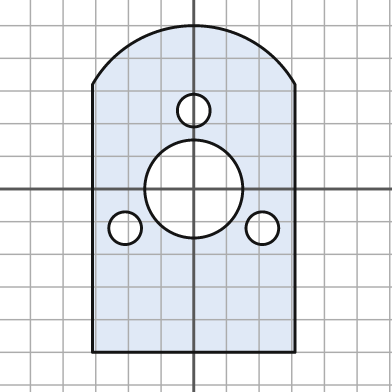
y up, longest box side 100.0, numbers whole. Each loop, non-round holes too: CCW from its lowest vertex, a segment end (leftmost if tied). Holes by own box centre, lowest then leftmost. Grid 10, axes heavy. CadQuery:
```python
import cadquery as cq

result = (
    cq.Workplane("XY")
    .moveTo(-31.0, -50.0)
    .lineTo(31.0, -50.0)
    .lineTo(31.0, 32.0)
    .threePointArc((0.0, 50.0), (-31.0, 32.0))
    .close()
    .moveTo(-21.0, -12.0)
    .circle(5.0)
    .moveTo(21.0, -12.0)
    .circle(5.0)
    .moveTo(0.0, 0.0)
    .circle(15.0)
    .moveTo(0.0, 24.0)
    .circle(5.0)
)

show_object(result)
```